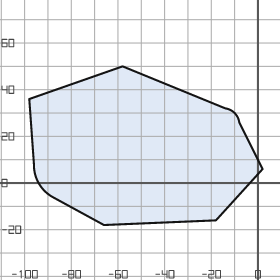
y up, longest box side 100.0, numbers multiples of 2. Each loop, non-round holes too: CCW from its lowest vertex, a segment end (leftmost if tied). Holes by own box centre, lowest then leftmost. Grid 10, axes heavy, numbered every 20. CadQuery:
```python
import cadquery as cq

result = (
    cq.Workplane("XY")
    .moveTo(-66.0, -18.0)
    .lineTo(-18.0, -16.0)
    .lineTo(2.0, 6.0)
    .lineTo(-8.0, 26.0)
    .threePointArc((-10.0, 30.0), (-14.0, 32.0))
    .lineTo(-58.0, 50.0)
    .lineTo(-98.0, 36.0)
    .lineTo(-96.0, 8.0)
    .threePointArc((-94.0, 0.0), (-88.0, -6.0))
    .close()
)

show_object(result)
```